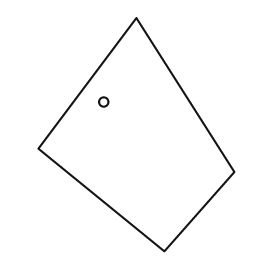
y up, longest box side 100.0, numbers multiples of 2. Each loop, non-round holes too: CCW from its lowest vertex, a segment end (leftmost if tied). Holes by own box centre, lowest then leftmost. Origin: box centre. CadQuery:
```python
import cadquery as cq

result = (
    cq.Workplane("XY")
    .moveTo(12.0, -50.0)
    .lineTo(42.0, -16.0)
    .lineTo(0.0, 50.0)
    .lineTo(-42.0, -6.0)
    .close()
    .moveTo(-14.0, 14.0)
    .circle(2.0)
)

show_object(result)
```